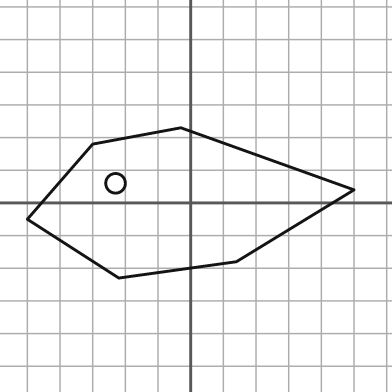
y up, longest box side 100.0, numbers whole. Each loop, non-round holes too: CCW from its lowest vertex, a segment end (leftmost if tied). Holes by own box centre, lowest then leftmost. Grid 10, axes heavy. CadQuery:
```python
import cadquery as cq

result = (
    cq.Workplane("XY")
    .moveTo(-22.0, -23.0)
    .lineTo(14.0, -18.0)
    .lineTo(50.0, 4.0)
    .lineTo(-3.0, 23.0)
    .lineTo(-30.0, 18.0)
    .lineTo(-50.0, -5.0)
    .close()
    .moveTo(-23.0, 6.0)
    .circle(3.0)
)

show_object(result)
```